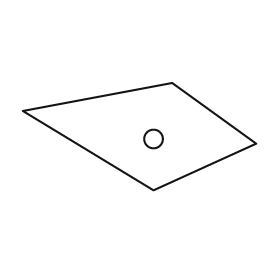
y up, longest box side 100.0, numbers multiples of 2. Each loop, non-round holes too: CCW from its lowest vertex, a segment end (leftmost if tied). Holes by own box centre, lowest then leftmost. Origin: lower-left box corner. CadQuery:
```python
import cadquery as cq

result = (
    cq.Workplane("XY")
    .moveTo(56.0, 0.0)
    .lineTo(100.0, 20.0)
    .lineTo(64.0, 46.0)
    .lineTo(0.0, 34.0)
    .close()
    .moveTo(56.0, 22.0)
    .circle(4.0)
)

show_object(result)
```